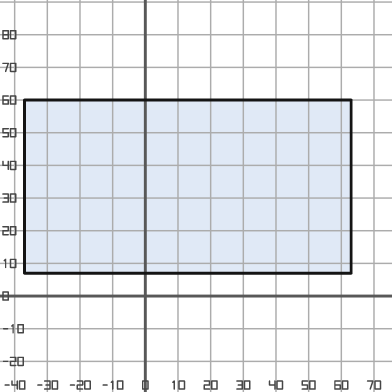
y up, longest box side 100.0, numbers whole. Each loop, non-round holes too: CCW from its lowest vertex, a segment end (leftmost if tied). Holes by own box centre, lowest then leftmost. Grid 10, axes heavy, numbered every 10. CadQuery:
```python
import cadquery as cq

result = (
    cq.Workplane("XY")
    .moveTo(-37.0, 7.0)
    .lineTo(63.0, 7.0)
    .lineTo(63.0, 60.0)
    .lineTo(-37.0, 60.0)
    .close()
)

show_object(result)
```